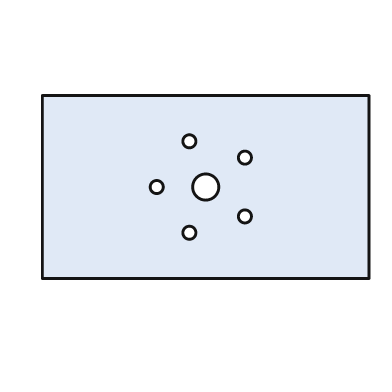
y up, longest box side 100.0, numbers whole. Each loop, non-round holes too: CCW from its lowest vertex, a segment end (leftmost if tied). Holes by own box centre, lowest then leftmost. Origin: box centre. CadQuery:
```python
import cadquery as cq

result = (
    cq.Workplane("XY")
    .moveTo(-50.0, -28.0)
    .lineTo(50.0, -28.0)
    .lineTo(50.0, 28.0)
    .lineTo(-50.0, 28.0)
    .close()
    .moveTo(-5.0, -14.0)
    .circle(2.0)
    .moveTo(12.0, -9.0)
    .circle(2.0)
    .moveTo(-15.0, 0.0)
    .circle(2.0)
    .moveTo(0.0, 0.0)
    .circle(4.0)
    .moveTo(12.0, 9.0)
    .circle(2.0)
    .moveTo(-5.0, 14.0)
    .circle(2.0)
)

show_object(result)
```